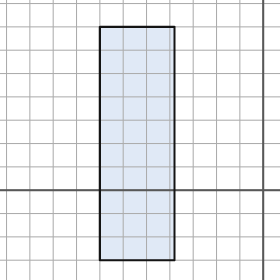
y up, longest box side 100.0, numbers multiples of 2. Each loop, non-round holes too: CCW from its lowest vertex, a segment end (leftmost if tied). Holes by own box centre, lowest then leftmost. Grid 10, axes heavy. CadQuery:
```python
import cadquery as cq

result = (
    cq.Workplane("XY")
    .moveTo(-70.0, -30.0)
    .lineTo(-38.0, -30.0)
    .lineTo(-38.0, 70.0)
    .lineTo(-70.0, 70.0)
    .close()
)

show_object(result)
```